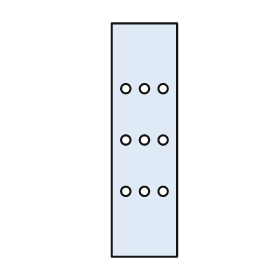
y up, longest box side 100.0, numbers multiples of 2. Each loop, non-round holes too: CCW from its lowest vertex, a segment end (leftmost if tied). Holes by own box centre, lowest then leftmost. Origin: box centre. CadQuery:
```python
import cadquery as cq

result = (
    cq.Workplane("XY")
    .moveTo(-14.0, -50.0)
    .lineTo(14.0, -50.0)
    .lineTo(14.0, 50.0)
    .lineTo(-14.0, 50.0)
    .close()
    .moveTo(-8.0, -22.0)
    .circle(2.0)
    .moveTo(0.0, -22.0)
    .circle(2.0)
    .moveTo(8.0, -22.0)
    .circle(2.0)
    .moveTo(-8.0, 0.0)
    .circle(2.0)
    .moveTo(0.0, 0.0)
    .circle(2.0)
    .moveTo(8.0, 0.0)
    .circle(2.0)
    .moveTo(-8.0, 22.0)
    .circle(2.0)
    .moveTo(0.0, 22.0)
    .circle(2.0)
    .moveTo(8.0, 22.0)
    .circle(2.0)
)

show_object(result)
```